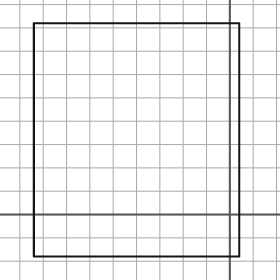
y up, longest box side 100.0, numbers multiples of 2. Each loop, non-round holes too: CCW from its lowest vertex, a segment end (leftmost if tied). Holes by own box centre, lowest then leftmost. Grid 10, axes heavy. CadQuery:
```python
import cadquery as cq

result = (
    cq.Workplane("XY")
    .moveTo(-84.0, -18.0)
    .lineTo(4.0, -18.0)
    .lineTo(4.0, 82.0)
    .lineTo(-84.0, 82.0)
    .close()
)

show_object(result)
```